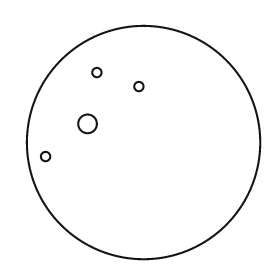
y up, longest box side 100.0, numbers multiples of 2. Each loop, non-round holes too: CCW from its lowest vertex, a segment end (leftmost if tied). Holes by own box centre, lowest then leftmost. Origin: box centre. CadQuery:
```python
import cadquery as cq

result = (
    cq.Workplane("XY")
    .moveTo(0.0, 0.0)
    .circle(50.0)
    .moveTo(-42.0, -6.0)
    .circle(2.0)
    .moveTo(-24.0, 8.0)
    .circle(4.0)
    .moveTo(-2.0, 24.0)
    .circle(2.0)
    .moveTo(-20.0, 30.0)
    .circle(2.0)
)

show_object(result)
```